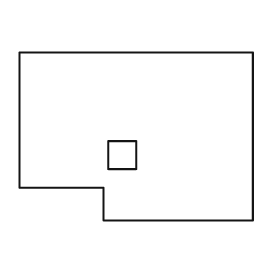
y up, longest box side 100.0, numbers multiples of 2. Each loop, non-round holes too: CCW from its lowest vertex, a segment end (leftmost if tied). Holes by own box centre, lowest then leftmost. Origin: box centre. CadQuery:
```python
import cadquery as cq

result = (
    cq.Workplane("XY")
    .moveTo(-14.0, -36.0)
    .lineTo(50.0, -36.0)
    .lineTo(50.0, 36.0)
    .lineTo(-50.0, 36.0)
    .lineTo(-50.0, -22.0)
    .lineTo(-14.0, -22.0)
    .close()
    .moveTo(-12.0, -14.0)
    .lineTo(0.0, -14.0)
    .lineTo(0.0, -2.0)
    .lineTo(-12.0, -2.0)
    .close()
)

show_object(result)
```